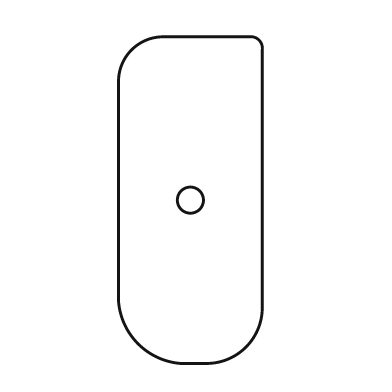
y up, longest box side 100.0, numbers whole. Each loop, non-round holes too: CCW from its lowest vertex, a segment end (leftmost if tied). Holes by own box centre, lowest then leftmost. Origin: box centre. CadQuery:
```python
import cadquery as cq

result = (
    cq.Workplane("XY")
    .moveTo(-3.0, -50.0)
    .lineTo(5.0, -50.0)
    .threePointArc((17.0, -45.0), (22.0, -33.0))
    .lineTo(22.0, 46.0)
    .threePointArc((21.0, 49.0), (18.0, 50.0))
    .lineTo(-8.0, 50.0)
    .threePointArc((-18.0, 46.0), (-22.0, 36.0))
    .lineTo(-22.0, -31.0)
    .threePointArc((-16.0, -44.0), (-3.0, -50.0))
    .close()
    .moveTo(0.0, 0.0)
    .circle(4.0)
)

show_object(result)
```